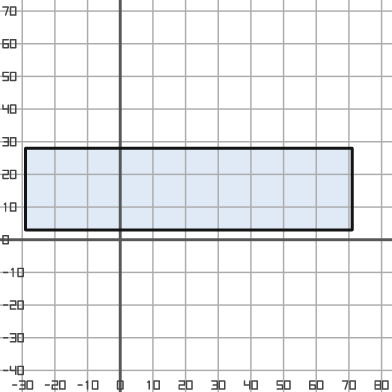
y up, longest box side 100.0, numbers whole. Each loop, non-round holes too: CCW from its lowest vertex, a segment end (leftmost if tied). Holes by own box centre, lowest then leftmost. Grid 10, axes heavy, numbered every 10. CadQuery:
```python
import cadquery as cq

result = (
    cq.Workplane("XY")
    .moveTo(-29.0, 3.0)
    .lineTo(71.0, 3.0)
    .lineTo(71.0, 28.0)
    .lineTo(-29.0, 28.0)
    .close()
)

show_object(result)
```